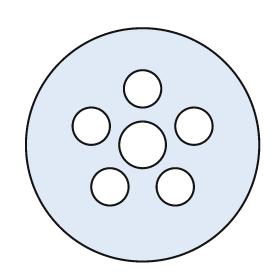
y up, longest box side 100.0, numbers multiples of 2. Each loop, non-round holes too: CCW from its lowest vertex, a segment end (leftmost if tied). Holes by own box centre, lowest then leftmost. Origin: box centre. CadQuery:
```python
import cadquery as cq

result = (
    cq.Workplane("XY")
    .moveTo(0.0, 0.0)
    .circle(50.0)
    .moveTo(-14.0, -18.0)
    .circle(8.0)
    .moveTo(14.0, -18.0)
    .circle(8.0)
    .moveTo(0.0, 0.0)
    .circle(10.0)
    .moveTo(-22.0, 8.0)
    .circle(8.0)
    .moveTo(22.0, 8.0)
    .circle(8.0)
    .moveTo(0.0, 24.0)
    .circle(8.0)
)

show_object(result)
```